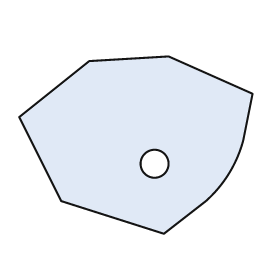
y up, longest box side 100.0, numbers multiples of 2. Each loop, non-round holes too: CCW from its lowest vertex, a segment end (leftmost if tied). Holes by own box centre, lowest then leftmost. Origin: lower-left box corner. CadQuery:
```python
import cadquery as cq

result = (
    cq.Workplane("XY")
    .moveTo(62.0, 0.0)
    .lineTo(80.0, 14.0)
    .threePointArc((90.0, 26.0), (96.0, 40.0))
    .lineTo(100.0, 60.0)
    .lineTo(64.0, 76.0)
    .lineTo(30.0, 74.0)
    .lineTo(0.0, 50.0)
    .lineTo(18.0, 14.0)
    .close()
    .moveTo(58.0, 30.0)
    .circle(6.0)
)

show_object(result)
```